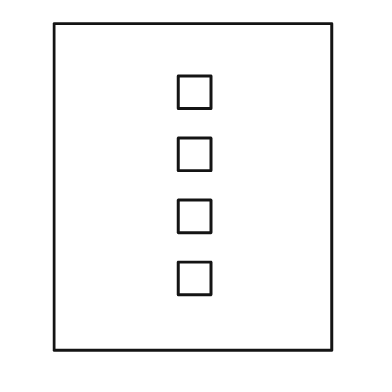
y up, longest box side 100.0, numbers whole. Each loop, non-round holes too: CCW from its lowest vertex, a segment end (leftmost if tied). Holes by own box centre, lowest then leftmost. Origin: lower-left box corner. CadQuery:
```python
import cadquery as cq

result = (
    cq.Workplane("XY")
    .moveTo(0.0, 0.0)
    .lineTo(85.0, 0.0)
    .lineTo(85.0, 100.0)
    .lineTo(0.0, 100.0)
    .close()
    .moveTo(38.0, 17.0)
    .lineTo(48.0, 17.0)
    .lineTo(48.0, 27.0)
    .lineTo(38.0, 27.0)
    .close()
    .moveTo(38.0, 36.0)
    .lineTo(48.0, 36.0)
    .lineTo(48.0, 46.0)
    .lineTo(38.0, 46.0)
    .close()
    .moveTo(38.0, 55.0)
    .lineTo(48.0, 55.0)
    .lineTo(48.0, 65.0)
    .lineTo(38.0, 65.0)
    .close()
    .moveTo(38.0, 74.0)
    .lineTo(48.0, 74.0)
    .lineTo(48.0, 84.0)
    .lineTo(38.0, 84.0)
    .close()
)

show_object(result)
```